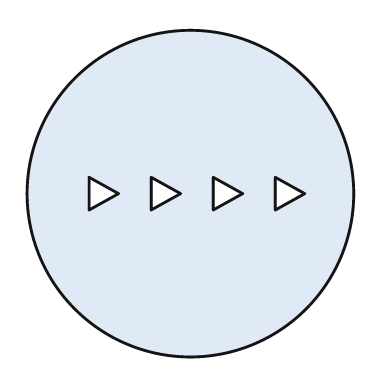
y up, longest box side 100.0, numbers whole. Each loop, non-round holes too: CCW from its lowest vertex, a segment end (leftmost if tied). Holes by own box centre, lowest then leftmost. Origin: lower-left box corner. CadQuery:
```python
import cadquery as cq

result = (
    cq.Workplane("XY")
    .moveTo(50.0, 50.0)
    .circle(50.0)
    .moveTo(19.0, 45.0)
    .lineTo(28.0, 50.0)
    .lineTo(19.0, 55.0)
    .close()
    .moveTo(38.0, 45.0)
    .lineTo(47.0, 50.0)
    .lineTo(38.0, 55.0)
    .close()
    .moveTo(57.0, 45.0)
    .lineTo(66.0, 50.0)
    .lineTo(57.0, 55.0)
    .close()
    .moveTo(76.0, 45.0)
    .lineTo(85.0, 50.0)
    .lineTo(76.0, 55.0)
    .close()
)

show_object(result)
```